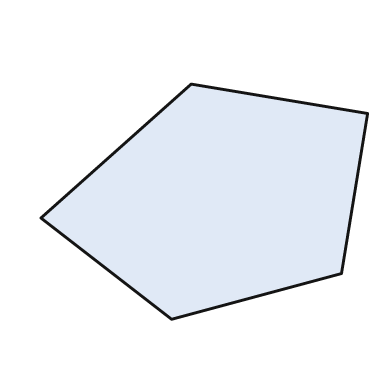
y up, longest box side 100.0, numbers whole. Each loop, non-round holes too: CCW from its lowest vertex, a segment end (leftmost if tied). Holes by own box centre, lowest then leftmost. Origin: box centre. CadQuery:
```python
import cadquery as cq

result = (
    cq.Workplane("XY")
    .moveTo(-10.0, -36.0)
    .lineTo(42.0, -22.0)
    .lineTo(50.0, 27.0)
    .lineTo(-4.0, 36.0)
    .lineTo(-50.0, -5.0)
    .close()
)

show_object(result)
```